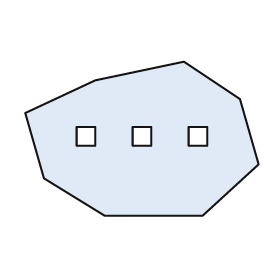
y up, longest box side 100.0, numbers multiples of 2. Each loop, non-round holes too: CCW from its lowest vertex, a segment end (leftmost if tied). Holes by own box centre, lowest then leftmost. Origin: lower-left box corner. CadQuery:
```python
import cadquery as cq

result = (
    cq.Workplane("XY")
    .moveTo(34.0, 0.0)
    .lineTo(76.0, 0.0)
    .lineTo(100.0, 22.0)
    .lineTo(92.0, 50.0)
    .lineTo(68.0, 66.0)
    .lineTo(30.0, 58.0)
    .lineTo(0.0, 44.0)
    .lineTo(8.0, 16.0)
    .close()
    .moveTo(22.0, 30.0)
    .lineTo(30.0, 30.0)
    .lineTo(30.0, 38.0)
    .lineTo(22.0, 38.0)
    .close()
    .moveTo(46.0, 30.0)
    .lineTo(54.0, 30.0)
    .lineTo(54.0, 38.0)
    .lineTo(46.0, 38.0)
    .close()
    .moveTo(70.0, 30.0)
    .lineTo(78.0, 30.0)
    .lineTo(78.0, 38.0)
    .lineTo(70.0, 38.0)
    .close()
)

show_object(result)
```